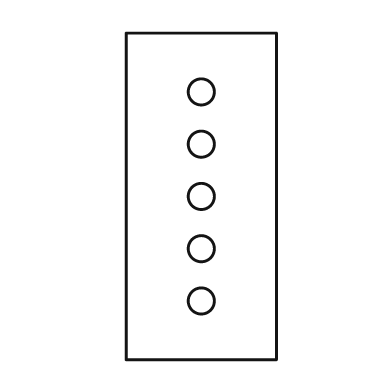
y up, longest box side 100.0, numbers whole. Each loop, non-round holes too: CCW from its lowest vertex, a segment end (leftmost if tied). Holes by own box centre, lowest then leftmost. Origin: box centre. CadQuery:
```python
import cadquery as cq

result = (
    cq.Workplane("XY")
    .moveTo(-23.0, -50.0)
    .lineTo(23.0, -50.0)
    .lineTo(23.0, 50.0)
    .lineTo(-23.0, 50.0)
    .close()
    .moveTo(0.0, -32.0)
    .circle(4.0)
    .moveTo(0.0, -16.0)
    .circle(4.0)
    .moveTo(0.0, 0.0)
    .circle(4.0)
    .moveTo(0.0, 16.0)
    .circle(4.0)
    .moveTo(0.0, 32.0)
    .circle(4.0)
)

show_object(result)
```